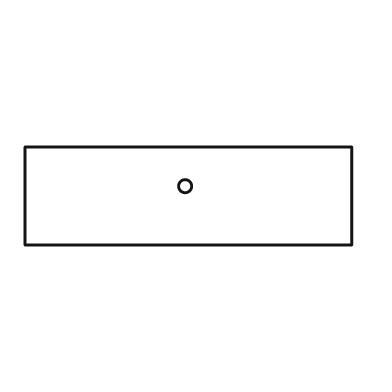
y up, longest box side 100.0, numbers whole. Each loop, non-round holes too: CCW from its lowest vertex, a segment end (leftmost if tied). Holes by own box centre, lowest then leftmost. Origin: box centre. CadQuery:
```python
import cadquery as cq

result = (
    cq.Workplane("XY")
    .moveTo(-50.0, -15.0)
    .lineTo(50.0, -15.0)
    .lineTo(50.0, 15.0)
    .lineTo(-50.0, 15.0)
    .close()
    .moveTo(-1.0, 3.0)
    .circle(2.0)
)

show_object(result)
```